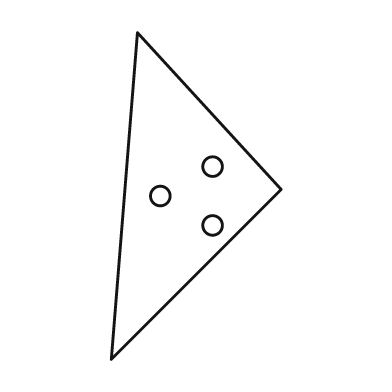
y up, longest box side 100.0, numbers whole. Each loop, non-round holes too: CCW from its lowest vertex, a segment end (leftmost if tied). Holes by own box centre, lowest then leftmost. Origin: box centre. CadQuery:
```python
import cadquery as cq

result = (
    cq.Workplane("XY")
    .moveTo(-26.0, -50.0)
    .lineTo(26.0, 2.0)
    .lineTo(-18.0, 50.0)
    .close()
    .moveTo(5.0, -9.0)
    .circle(3.0)
    .moveTo(-11.0, 0.0)
    .circle(3.0)
    .moveTo(5.0, 9.0)
    .circle(3.0)
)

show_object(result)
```